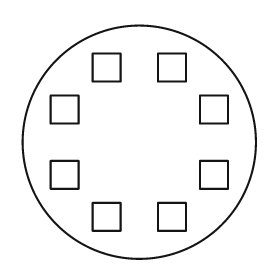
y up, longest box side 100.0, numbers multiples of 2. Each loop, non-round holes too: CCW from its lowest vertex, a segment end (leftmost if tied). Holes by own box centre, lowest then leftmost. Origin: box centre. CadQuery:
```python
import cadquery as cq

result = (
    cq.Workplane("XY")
    .moveTo(0.0, 0.0)
    .circle(50.0)
    .moveTo(-20.0, -38.0)
    .lineTo(-8.0, -38.0)
    .lineTo(-8.0, -26.0)
    .lineTo(-20.0, -26.0)
    .close()
    .moveTo(8.0, -38.0)
    .lineTo(20.0, -38.0)
    .lineTo(20.0, -26.0)
    .lineTo(8.0, -26.0)
    .close()
    .moveTo(-38.0, -20.0)
    .lineTo(-26.0, -20.0)
    .lineTo(-26.0, -8.0)
    .lineTo(-38.0, -8.0)
    .close()
    .moveTo(26.0, -20.0)
    .lineTo(38.0, -20.0)
    .lineTo(38.0, -8.0)
    .lineTo(26.0, -8.0)
    .close()
    .moveTo(-38.0, 8.0)
    .lineTo(-26.0, 8.0)
    .lineTo(-26.0, 20.0)
    .lineTo(-38.0, 20.0)
    .close()
    .moveTo(26.0, 8.0)
    .lineTo(38.0, 8.0)
    .lineTo(38.0, 20.0)
    .lineTo(26.0, 20.0)
    .close()
    .moveTo(-20.0, 26.0)
    .lineTo(-8.0, 26.0)
    .lineTo(-8.0, 38.0)
    .lineTo(-20.0, 38.0)
    .close()
    .moveTo(8.0, 26.0)
    .lineTo(20.0, 26.0)
    .lineTo(20.0, 38.0)
    .lineTo(8.0, 38.0)
    .close()
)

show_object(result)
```